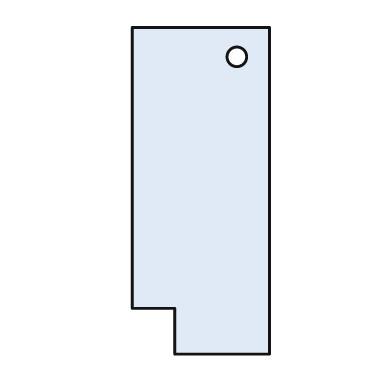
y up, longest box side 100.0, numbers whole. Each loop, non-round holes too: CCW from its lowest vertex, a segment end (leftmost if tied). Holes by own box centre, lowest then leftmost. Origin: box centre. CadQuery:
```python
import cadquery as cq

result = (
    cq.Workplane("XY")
    .moveTo(-8.0, -50.0)
    .lineTo(21.0, -50.0)
    .lineTo(21.0, 50.0)
    .lineTo(-21.0, 50.0)
    .lineTo(-21.0, -36.0)
    .lineTo(-8.0, -36.0)
    .close()
    .moveTo(11.0, 41.0)
    .circle(3.0)
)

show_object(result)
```